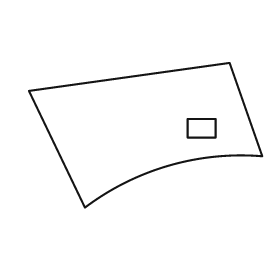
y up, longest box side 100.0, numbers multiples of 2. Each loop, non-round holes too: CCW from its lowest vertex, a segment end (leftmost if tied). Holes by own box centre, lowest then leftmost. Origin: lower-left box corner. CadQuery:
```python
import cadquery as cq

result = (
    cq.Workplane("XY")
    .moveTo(24.0, 0.0)
    .threePointArc((60.0, 18.0), (100.0, 22.0))
    .lineTo(86.0, 62.0)
    .lineTo(0.0, 50.0)
    .close()
    .moveTo(68.0, 30.0)
    .lineTo(80.0, 30.0)
    .lineTo(80.0, 38.0)
    .lineTo(68.0, 38.0)
    .close()
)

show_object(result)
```